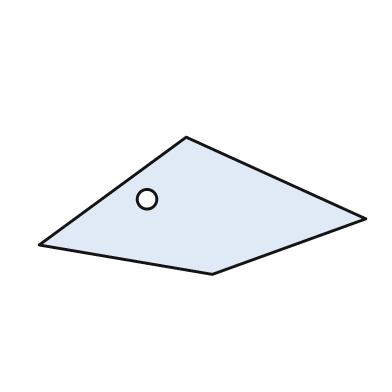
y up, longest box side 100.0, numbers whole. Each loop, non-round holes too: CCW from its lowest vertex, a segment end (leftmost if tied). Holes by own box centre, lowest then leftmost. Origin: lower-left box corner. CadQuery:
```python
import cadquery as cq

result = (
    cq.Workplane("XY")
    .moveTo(53.0, 0.0)
    .lineTo(100.0, 17.0)
    .lineTo(45.0, 42.0)
    .lineTo(0.0, 9.0)
    .close()
    .moveTo(33.0, 23.0)
    .circle(3.0)
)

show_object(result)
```